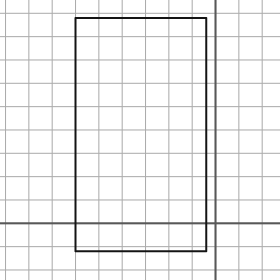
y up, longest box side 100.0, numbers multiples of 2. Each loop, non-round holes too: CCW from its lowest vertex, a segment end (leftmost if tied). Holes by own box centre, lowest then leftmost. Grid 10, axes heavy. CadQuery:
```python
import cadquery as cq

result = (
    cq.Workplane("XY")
    .moveTo(-60.0, -12.0)
    .lineTo(-4.0, -12.0)
    .lineTo(-4.0, 88.0)
    .lineTo(-60.0, 88.0)
    .close()
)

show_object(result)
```